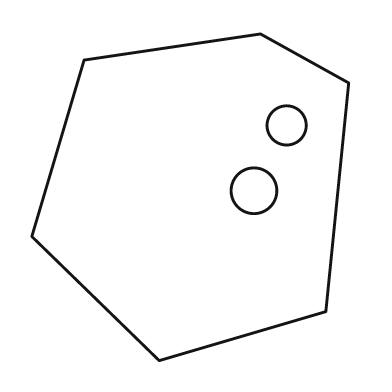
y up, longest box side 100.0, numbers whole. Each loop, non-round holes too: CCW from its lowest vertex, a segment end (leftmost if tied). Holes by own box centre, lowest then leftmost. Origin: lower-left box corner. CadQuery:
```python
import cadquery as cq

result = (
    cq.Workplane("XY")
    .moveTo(39.0, 0.0)
    .lineTo(90.0, 15.0)
    .lineTo(97.0, 85.0)
    .lineTo(70.0, 100.0)
    .lineTo(16.0, 92.0)
    .lineTo(0.0, 38.0)
    .close()
    .moveTo(68.0, 52.0)
    .circle(7.0)
    .moveTo(78.0, 72.0)
    .circle(6.0)
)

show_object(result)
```